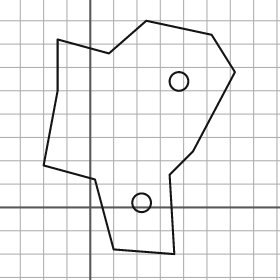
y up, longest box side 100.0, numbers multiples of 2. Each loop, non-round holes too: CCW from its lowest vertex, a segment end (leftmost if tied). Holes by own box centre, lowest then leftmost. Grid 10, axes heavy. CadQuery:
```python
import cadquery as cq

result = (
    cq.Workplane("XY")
    .moveTo(36.0, -20.0)
    .lineTo(34.0, 14.0)
    .lineTo(44.0, 24.0)
    .lineTo(62.0, 58.0)
    .lineTo(52.0, 74.0)
    .lineTo(24.0, 80.0)
    .lineTo(8.0, 66.0)
    .lineTo(-14.0, 72.0)
    .lineTo(-14.0, 50.0)
    .lineTo(-20.0, 18.0)
    .lineTo(2.0, 12.0)
    .lineTo(10.0, -18.0)
    .close()
    .moveTo(22.0, 2.0)
    .circle(4.0)
    .moveTo(38.0, 54.0)
    .circle(4.0)
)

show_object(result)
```